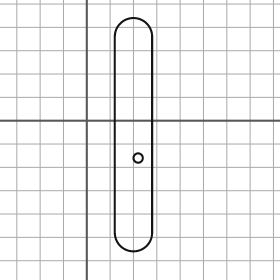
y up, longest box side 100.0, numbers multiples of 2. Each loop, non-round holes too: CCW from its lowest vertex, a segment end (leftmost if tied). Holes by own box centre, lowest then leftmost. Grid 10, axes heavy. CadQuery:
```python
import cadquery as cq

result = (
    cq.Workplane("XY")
    .moveTo(12.0, -48.0)
    .threePointArc((20.0, -56.0), (28.0, -48.0))
    .lineTo(28.0, 36.0)
    .threePointArc((20.0, 44.0), (12.0, 36.0))
    .close()
    .moveTo(22.0, -16.0)
    .circle(2.0)
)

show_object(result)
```